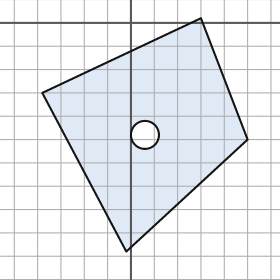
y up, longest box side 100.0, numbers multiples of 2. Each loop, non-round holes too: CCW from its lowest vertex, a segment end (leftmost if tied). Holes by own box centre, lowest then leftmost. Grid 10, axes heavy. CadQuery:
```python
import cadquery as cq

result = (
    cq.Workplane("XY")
    .moveTo(-2.0, -98.0)
    .lineTo(50.0, -50.0)
    .lineTo(30.0, 2.0)
    .lineTo(-38.0, -30.0)
    .close()
    .moveTo(6.0, -48.0)
    .circle(6.0)
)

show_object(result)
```